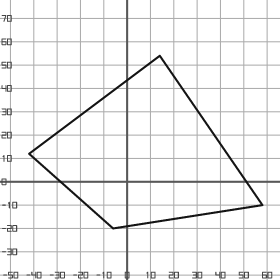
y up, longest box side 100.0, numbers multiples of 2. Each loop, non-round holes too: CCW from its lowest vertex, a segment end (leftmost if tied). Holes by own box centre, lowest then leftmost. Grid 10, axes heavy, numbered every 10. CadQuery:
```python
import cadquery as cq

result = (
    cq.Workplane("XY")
    .moveTo(-6.0, -20.0)
    .lineTo(58.0, -10.0)
    .lineTo(14.0, 54.0)
    .lineTo(-42.0, 12.0)
    .close()
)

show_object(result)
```